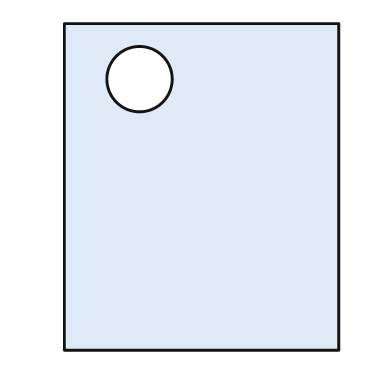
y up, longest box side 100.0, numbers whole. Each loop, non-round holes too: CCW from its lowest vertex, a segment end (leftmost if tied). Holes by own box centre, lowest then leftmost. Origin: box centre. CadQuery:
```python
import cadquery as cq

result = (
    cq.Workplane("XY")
    .moveTo(-42.0, -50.0)
    .lineTo(42.0, -50.0)
    .lineTo(42.0, 50.0)
    .lineTo(-42.0, 50.0)
    .close()
    .moveTo(-19.0, 33.0)
    .circle(10.0)
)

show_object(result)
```